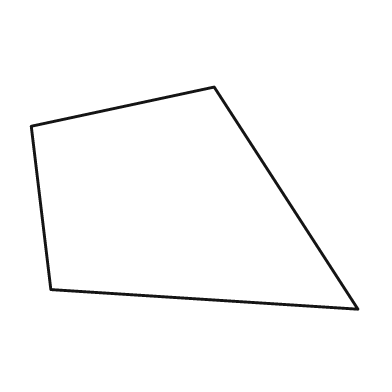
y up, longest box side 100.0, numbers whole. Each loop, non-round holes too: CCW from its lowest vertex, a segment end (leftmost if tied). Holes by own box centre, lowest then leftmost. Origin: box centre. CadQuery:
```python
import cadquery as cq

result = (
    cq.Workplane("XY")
    .moveTo(50.0, -34.0)
    .lineTo(6.0, 34.0)
    .lineTo(-50.0, 22.0)
    .lineTo(-44.0, -28.0)
    .close()
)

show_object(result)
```